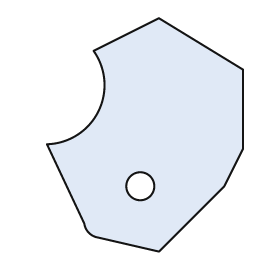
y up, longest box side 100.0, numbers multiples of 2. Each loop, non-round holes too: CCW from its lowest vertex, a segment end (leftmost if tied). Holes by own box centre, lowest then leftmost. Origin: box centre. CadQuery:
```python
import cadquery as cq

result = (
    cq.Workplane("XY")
    .moveTo(6.0, -50.0)
    .lineTo(34.0, -22.0)
    .lineTo(42.0, -6.0)
    .lineTo(42.0, 28.0)
    .lineTo(6.0, 50.0)
    .lineTo(-22.0, 36.0)
    .threePointArc((-20.0, 10.0), (-42.0, -4.0))
    .lineTo(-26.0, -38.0)
    .threePointArc((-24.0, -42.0), (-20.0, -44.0))
    .close()
    .moveTo(-2.0, -22.0)
    .circle(6.0)
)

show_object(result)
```